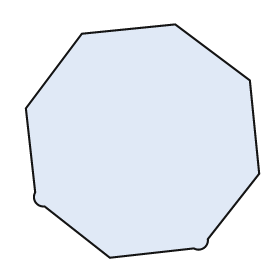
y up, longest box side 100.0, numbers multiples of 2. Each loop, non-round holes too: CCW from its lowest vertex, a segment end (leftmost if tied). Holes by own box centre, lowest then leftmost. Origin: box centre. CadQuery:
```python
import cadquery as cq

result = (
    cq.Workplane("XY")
    .moveTo(-14.0, -50.0)
    .lineTo(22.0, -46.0)
    .threePointArc((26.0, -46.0), (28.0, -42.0))
    .lineTo(50.0, -14.0)
    .lineTo(46.0, 26.0)
    .lineTo(14.0, 50.0)
    .lineTo(-26.0, 46.0)
    .lineTo(-50.0, 14.0)
    .lineTo(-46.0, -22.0)
    .threePointArc((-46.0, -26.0), (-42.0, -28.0))
    .close()
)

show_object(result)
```